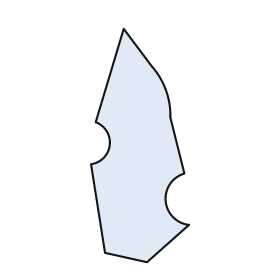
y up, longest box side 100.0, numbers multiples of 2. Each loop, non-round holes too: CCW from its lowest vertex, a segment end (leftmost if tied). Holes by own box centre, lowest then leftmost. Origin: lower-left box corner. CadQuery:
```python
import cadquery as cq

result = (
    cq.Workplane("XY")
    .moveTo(24.0, 0.0)
    .lineTo(42.0, 16.0)
    .threePointArc((32.0, 26.0), (40.0, 38.0))
    .lineTo(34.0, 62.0)
    .threePointArc((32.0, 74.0), (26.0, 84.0))
    .lineTo(14.0, 100.0)
    .lineTo(2.0, 60.0)
    .threePointArc((8.0, 50.0), (0.0, 42.0))
    .lineTo(6.0, 4.0)
    .close()
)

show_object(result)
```